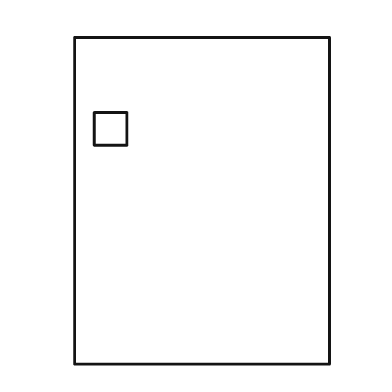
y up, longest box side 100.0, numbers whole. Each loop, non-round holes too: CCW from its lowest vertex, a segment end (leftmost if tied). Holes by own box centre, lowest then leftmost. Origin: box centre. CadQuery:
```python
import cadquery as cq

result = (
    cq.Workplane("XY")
    .moveTo(-39.0, -50.0)
    .lineTo(39.0, -50.0)
    .lineTo(39.0, 50.0)
    .lineTo(-39.0, 50.0)
    .close()
    .moveTo(-33.0, 17.0)
    .lineTo(-23.0, 17.0)
    .lineTo(-23.0, 27.0)
    .lineTo(-33.0, 27.0)
    .close()
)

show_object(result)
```